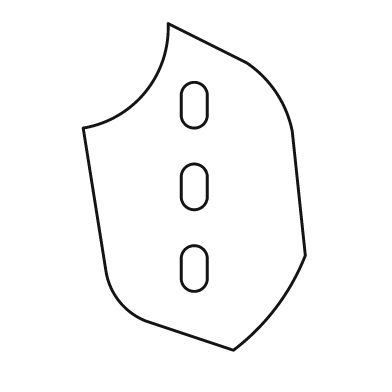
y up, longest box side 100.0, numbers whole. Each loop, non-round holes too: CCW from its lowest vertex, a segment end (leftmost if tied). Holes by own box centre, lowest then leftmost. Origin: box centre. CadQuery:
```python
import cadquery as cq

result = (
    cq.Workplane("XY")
    .moveTo(12.0, -50.0)
    .threePointArc((25.0, -37.0), (34.0, -21.0))
    .lineTo(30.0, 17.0)
    .threePointArc((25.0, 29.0), (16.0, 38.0))
    .lineTo(-8.0, 50.0)
    .threePointArc((-15.0, 29.0), (-34.0, 18.0))
    .lineTo(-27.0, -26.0)
    .threePointArc((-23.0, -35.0), (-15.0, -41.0))
    .close()
    .moveTo(-4.0, -28.0)
    .threePointArc((0.0, -32.0), (4.0, -28.0))
    .lineTo(4.0, -22.0)
    .threePointArc((0.0, -18.0), (-4.0, -22.0))
    .close()
    .moveTo(-4.0, -3.0)
    .threePointArc((0.0, -7.0), (4.0, -3.0))
    .lineTo(4.0, 3.0)
    .threePointArc((0.0, 7.0), (-4.0, 3.0))
    .close()
    .moveTo(-4.0, 22.0)
    .threePointArc((0.0, 18.0), (4.0, 22.0))
    .lineTo(4.0, 28.0)
    .threePointArc((0.0, 32.0), (-4.0, 28.0))
    .close()
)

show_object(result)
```